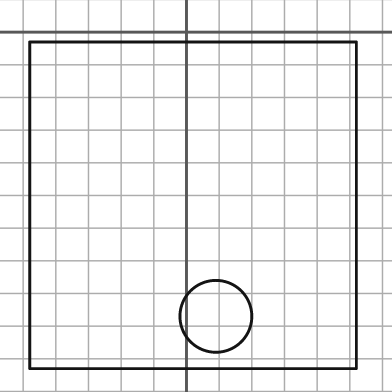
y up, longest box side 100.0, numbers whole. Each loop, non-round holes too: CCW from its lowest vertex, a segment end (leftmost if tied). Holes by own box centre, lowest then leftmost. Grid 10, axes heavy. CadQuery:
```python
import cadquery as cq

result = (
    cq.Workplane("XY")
    .moveTo(-48.0, -103.0)
    .lineTo(52.0, -103.0)
    .lineTo(52.0, -3.0)
    .lineTo(-48.0, -3.0)
    .close()
    .moveTo(9.0, -87.0)
    .circle(11.0)
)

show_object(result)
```